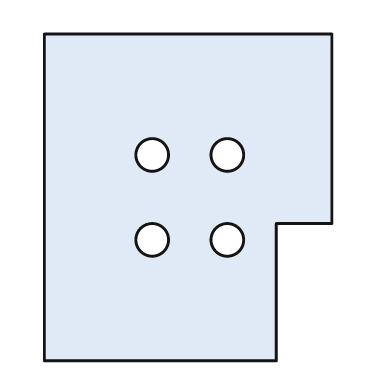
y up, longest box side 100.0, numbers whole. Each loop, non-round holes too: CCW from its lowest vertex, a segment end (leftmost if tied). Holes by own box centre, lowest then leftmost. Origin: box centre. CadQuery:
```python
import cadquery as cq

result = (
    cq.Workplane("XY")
    .moveTo(-44.0, -50.0)
    .lineTo(27.0, -50.0)
    .lineTo(27.0, -8.0)
    .lineTo(44.0, -8.0)
    .lineTo(44.0, 50.0)
    .lineTo(-44.0, 50.0)
    .close()
    .moveTo(-11.0, -13.0)
    .circle(5.0)
    .moveTo(12.0, -13.0)
    .circle(5.0)
    .moveTo(-11.0, 13.0)
    .circle(5.0)
    .moveTo(12.0, 13.0)
    .circle(5.0)
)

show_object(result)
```